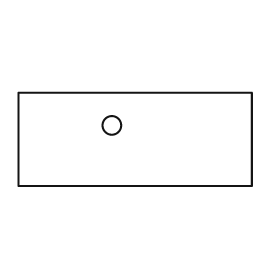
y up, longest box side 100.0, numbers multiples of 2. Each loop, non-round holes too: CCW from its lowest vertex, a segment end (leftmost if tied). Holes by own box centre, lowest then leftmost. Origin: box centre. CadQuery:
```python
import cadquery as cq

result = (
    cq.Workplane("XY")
    .moveTo(-50.0, -20.0)
    .lineTo(50.0, -20.0)
    .lineTo(50.0, 20.0)
    .lineTo(-50.0, 20.0)
    .close()
    .moveTo(-10.0, 6.0)
    .circle(4.0)
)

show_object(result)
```